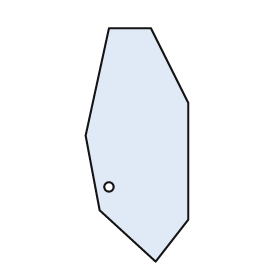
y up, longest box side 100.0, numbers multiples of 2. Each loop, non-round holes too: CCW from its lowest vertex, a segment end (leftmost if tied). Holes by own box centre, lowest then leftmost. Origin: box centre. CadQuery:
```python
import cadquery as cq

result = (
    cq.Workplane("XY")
    .moveTo(8.0, -50.0)
    .lineTo(22.0, -32.0)
    .lineTo(22.0, 18.0)
    .lineTo(6.0, 50.0)
    .lineTo(-12.0, 50.0)
    .lineTo(-22.0, 4.0)
    .lineTo(-16.0, -28.0)
    .close()
    .moveTo(-12.0, -18.0)
    .circle(2.0)
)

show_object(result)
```